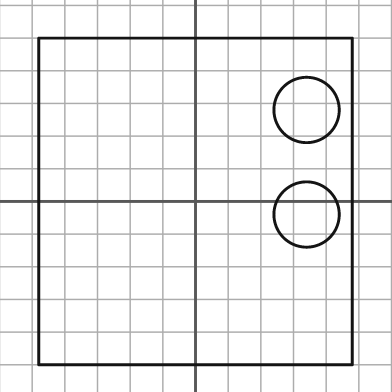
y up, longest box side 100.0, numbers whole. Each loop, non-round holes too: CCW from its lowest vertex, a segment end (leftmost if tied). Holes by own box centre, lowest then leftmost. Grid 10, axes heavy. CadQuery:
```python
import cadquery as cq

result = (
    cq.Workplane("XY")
    .moveTo(-48.0, -50.0)
    .lineTo(48.0, -50.0)
    .lineTo(48.0, 50.0)
    .lineTo(-48.0, 50.0)
    .close()
    .moveTo(34.0, -4.0)
    .circle(10.0)
    .moveTo(34.0, 28.0)
    .circle(10.0)
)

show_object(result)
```